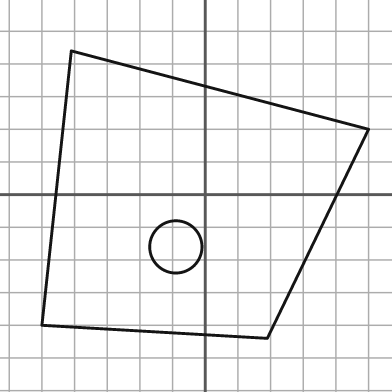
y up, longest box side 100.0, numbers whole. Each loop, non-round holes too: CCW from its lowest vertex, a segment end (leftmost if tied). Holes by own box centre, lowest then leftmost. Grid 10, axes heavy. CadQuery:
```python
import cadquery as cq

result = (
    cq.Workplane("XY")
    .moveTo(19.0, -44.0)
    .lineTo(50.0, 20.0)
    .lineTo(-41.0, 44.0)
    .lineTo(-50.0, -40.0)
    .close()
    .moveTo(-9.0, -16.0)
    .circle(8.0)
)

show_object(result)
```